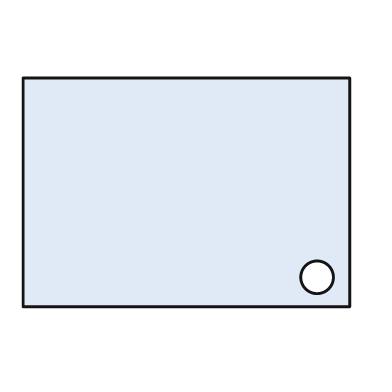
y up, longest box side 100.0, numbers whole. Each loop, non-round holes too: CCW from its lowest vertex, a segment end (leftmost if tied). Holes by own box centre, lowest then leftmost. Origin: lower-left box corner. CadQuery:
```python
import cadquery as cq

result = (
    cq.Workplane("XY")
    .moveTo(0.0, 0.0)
    .lineTo(100.0, 0.0)
    .lineTo(100.0, 70.0)
    .lineTo(0.0, 70.0)
    .close()
    .moveTo(90.0, 9.0)
    .circle(5.0)
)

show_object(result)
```